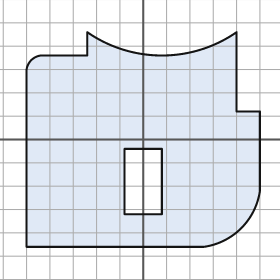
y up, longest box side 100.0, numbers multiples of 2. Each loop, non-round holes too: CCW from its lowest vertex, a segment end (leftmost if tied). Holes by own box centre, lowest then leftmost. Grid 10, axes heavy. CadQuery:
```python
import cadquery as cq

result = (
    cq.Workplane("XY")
    .moveTo(-50.0, -46.0)
    .lineTo(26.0, -46.0)
    .threePointArc((42.0, -38.0), (50.0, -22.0))
    .lineTo(50.0, 12.0)
    .lineTo(40.0, 12.0)
    .lineTo(40.0, 46.0)
    .threePointArc((8.0, 36.0), (-24.0, 46.0))
    .lineTo(-24.0, 36.0)
    .lineTo(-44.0, 36.0)
    .threePointArc((-48.0, 34.0), (-50.0, 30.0))
    .close()
    .moveTo(-8.0, -32.0)
    .lineTo(8.0, -32.0)
    .lineTo(8.0, -4.0)
    .lineTo(-8.0, -4.0)
    .close()
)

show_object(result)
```